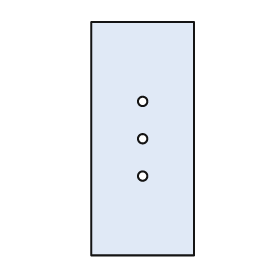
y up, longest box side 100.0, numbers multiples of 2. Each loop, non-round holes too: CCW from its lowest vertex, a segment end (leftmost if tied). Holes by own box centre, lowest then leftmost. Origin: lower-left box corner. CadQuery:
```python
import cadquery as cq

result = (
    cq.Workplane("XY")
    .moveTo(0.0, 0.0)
    .lineTo(44.0, 0.0)
    .lineTo(44.0, 100.0)
    .lineTo(0.0, 100.0)
    .close()
    .moveTo(22.0, 34.0)
    .circle(2.0)
    .moveTo(22.0, 50.0)
    .circle(2.0)
    .moveTo(22.0, 66.0)
    .circle(2.0)
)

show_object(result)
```